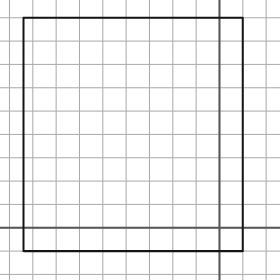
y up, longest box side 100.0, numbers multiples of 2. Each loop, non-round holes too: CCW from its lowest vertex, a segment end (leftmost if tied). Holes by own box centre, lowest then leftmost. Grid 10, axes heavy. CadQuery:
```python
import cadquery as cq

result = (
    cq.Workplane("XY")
    .moveTo(-84.0, -10.0)
    .lineTo(10.0, -10.0)
    .lineTo(10.0, 90.0)
    .lineTo(-84.0, 90.0)
    .close()
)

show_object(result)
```